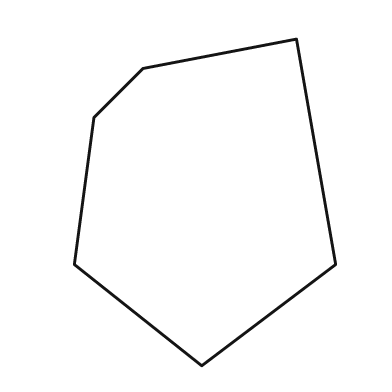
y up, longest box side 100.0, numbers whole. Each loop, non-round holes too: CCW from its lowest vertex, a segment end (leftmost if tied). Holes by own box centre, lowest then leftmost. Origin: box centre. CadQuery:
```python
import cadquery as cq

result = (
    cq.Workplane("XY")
    .moveTo(-1.0, -50.0)
    .lineTo(40.0, -19.0)
    .lineTo(28.0, 50.0)
    .lineTo(-19.0, 41.0)
    .lineTo(-34.0, 26.0)
    .lineTo(-40.0, -19.0)
    .close()
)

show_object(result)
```